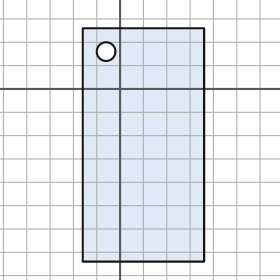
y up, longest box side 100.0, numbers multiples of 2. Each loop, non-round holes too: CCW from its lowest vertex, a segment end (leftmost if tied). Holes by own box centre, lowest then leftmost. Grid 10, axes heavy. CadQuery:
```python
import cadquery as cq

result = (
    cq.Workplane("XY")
    .moveTo(-16.0, -74.0)
    .lineTo(36.0, -74.0)
    .lineTo(36.0, 26.0)
    .lineTo(-16.0, 26.0)
    .close()
    .moveTo(-6.0, 16.0)
    .circle(4.0)
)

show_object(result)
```